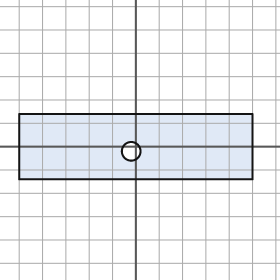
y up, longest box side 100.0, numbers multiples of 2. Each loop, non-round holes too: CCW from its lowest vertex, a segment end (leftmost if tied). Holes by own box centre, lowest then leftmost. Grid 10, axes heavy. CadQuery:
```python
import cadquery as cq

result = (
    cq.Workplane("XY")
    .moveTo(-50.0, -14.0)
    .lineTo(50.0, -14.0)
    .lineTo(50.0, 14.0)
    .lineTo(-50.0, 14.0)
    .close()
    .moveTo(-2.0, -2.0)
    .circle(4.0)
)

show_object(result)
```